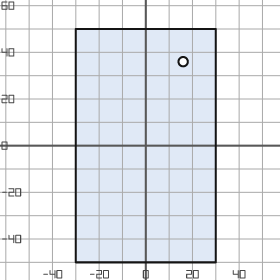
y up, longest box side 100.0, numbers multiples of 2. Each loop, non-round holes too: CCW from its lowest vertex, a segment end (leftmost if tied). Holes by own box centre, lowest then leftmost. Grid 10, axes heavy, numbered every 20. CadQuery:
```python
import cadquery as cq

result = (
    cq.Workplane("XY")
    .moveTo(-30.0, -50.0)
    .lineTo(30.0, -50.0)
    .lineTo(30.0, 50.0)
    .lineTo(-30.0, 50.0)
    .close()
    .moveTo(16.0, 36.0)
    .circle(2.0)
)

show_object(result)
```